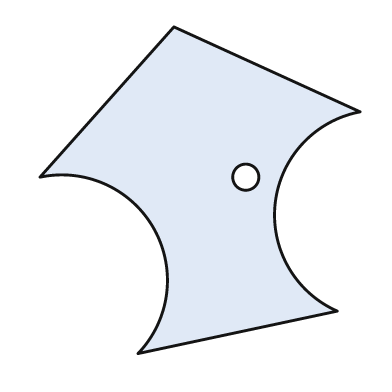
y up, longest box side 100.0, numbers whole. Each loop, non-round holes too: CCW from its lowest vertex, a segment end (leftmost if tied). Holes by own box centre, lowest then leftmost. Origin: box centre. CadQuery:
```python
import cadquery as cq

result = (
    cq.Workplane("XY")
    .moveTo(-19.0, -50.0)
    .lineTo(42.0, -37.0)
    .threePointArc((23.0, -4.0), (49.0, 24.0))
    .lineTo(-8.0, 50.0)
    .lineTo(-49.0, 4.0)
    .threePointArc((-14.0, -12.0), (-19.0, -50.0))
    .close()
    .moveTo(14.0, 4.0)
    .circle(4.0)
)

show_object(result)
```